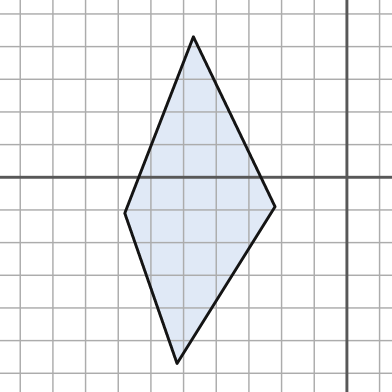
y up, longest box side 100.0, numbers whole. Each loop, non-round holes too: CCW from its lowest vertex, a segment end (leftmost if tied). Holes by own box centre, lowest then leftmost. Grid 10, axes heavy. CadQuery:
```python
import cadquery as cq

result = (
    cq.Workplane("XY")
    .moveTo(-52.0, -57.0)
    .lineTo(-22.0, -9.0)
    .lineTo(-47.0, 43.0)
    .lineTo(-68.0, -11.0)
    .close()
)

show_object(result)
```